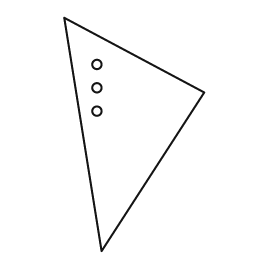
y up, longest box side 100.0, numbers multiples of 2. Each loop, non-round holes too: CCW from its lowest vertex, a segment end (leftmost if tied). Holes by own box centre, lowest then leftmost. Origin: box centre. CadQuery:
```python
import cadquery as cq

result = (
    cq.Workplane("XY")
    .moveTo(-14.0, -50.0)
    .lineTo(30.0, 18.0)
    .lineTo(-30.0, 50.0)
    .close()
    .moveTo(-16.0, 10.0)
    .circle(2.0)
    .moveTo(-16.0, 20.0)
    .circle(2.0)
    .moveTo(-16.0, 30.0)
    .circle(2.0)
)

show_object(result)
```